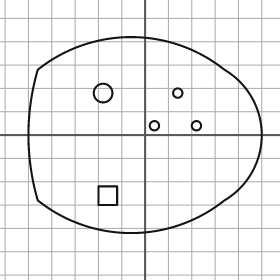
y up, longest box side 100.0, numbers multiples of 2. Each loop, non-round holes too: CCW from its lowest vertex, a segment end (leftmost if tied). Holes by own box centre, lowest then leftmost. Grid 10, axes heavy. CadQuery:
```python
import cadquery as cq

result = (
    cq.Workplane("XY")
    .moveTo(-46.0, -28.0)
    .threePointArc((-6.0, -42.0), (34.0, -28.0))
    .threePointArc((50.0, 0.0), (34.0, 28.0))
    .threePointArc((-6.0, 42.0), (-46.0, 28.0))
    .threePointArc((-50.0, 0.0), (-46.0, -28.0))
    .close()
    .moveTo(-20.0, -30.0)
    .lineTo(-12.0, -30.0)
    .lineTo(-12.0, -22.0)
    .lineTo(-20.0, -22.0)
    .close()
    .moveTo(4.0, 4.0)
    .circle(2.0)
    .moveTo(22.0, 4.0)
    .circle(2.0)
    .moveTo(-18.0, 18.0)
    .circle(4.0)
    .moveTo(14.0, 18.0)
    .circle(2.0)
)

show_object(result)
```